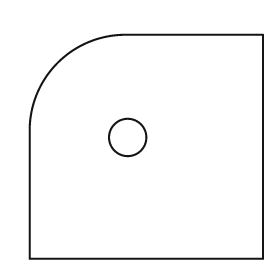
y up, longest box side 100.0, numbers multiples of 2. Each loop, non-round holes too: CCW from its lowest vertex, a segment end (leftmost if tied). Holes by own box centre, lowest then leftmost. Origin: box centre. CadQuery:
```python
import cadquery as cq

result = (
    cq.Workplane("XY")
    .moveTo(-50.0, -48.0)
    .lineTo(50.0, -48.0)
    .lineTo(50.0, 48.0)
    .lineTo(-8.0, 48.0)
    .threePointArc((-38.0, 36.0), (-50.0, 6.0))
    .close()
    .moveTo(-8.0, 4.0)
    .circle(8.0)
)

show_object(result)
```